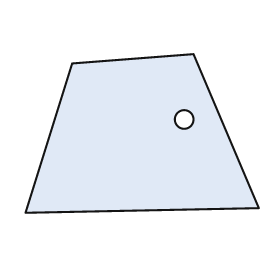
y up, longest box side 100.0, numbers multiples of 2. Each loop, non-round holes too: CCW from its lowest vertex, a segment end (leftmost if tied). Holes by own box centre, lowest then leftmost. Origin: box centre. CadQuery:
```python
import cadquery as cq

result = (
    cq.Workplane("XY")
    .moveTo(-50.0, -34.0)
    .lineTo(50.0, -32.0)
    .lineTo(22.0, 34.0)
    .lineTo(-30.0, 30.0)
    .close()
    .moveTo(18.0, 6.0)
    .circle(4.0)
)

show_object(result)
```